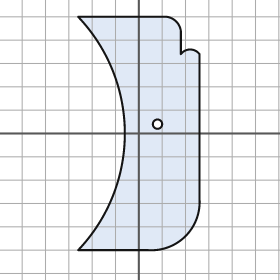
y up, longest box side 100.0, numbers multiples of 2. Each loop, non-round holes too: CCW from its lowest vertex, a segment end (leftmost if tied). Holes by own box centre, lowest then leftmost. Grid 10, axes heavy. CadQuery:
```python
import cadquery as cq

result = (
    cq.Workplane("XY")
    .moveTo(-26.0, -50.0)
    .lineTo(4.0, -50.0)
    .threePointArc((20.0, -44.0), (26.0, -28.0))
    .lineTo(26.0, 34.0)
    .threePointArc((22.0, 36.0), (18.0, 34.0))
    .lineTo(18.0, 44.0)
    .threePointArc((16.0, 48.0), (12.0, 50.0))
    .lineTo(-26.0, 50.0)
    .threePointArc((-6.0, 0.0), (-26.0, -50.0))
    .close()
    .moveTo(8.0, 4.0)
    .circle(2.0)
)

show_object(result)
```